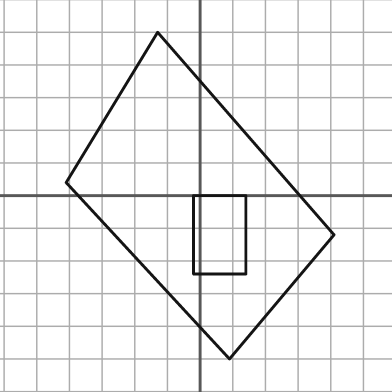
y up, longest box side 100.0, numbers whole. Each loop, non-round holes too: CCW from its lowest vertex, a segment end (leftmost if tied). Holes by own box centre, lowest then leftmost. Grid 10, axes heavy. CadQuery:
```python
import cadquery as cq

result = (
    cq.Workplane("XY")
    .moveTo(9.0, -50.0)
    .lineTo(41.0, -12.0)
    .lineTo(-13.0, 50.0)
    .lineTo(-41.0, 4.0)
    .close()
    .moveTo(-2.0, -24.0)
    .lineTo(14.0, -24.0)
    .lineTo(14.0, 0.0)
    .lineTo(-2.0, 0.0)
    .close()
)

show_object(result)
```